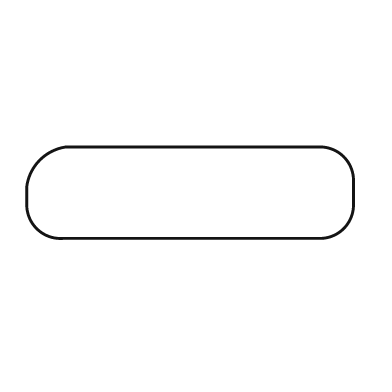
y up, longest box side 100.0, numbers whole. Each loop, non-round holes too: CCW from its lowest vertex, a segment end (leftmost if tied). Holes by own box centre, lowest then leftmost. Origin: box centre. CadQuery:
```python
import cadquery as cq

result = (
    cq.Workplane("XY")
    .moveTo(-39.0, -14.0)
    .lineTo(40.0, -14.0)
    .threePointArc((47.0, -11.0), (50.0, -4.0))
    .lineTo(50.0, 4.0)
    .threePointArc((47.0, 11.0), (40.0, 14.0))
    .lineTo(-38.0, 14.0)
    .threePointArc((-46.0, 10.0), (-50.0, 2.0))
    .lineTo(-50.0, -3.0)
    .threePointArc((-47.0, -11.0), (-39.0, -14.0))
    .close()
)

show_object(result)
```